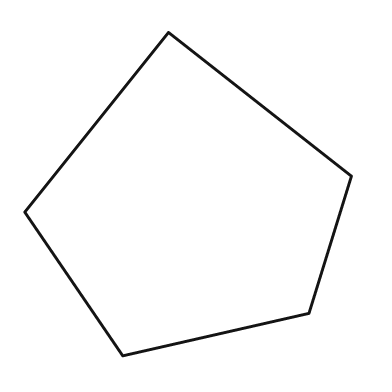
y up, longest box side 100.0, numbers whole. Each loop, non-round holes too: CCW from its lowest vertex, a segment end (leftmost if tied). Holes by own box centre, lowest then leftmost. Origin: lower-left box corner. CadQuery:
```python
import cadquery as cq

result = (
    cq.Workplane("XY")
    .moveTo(30.0, 0.0)
    .lineTo(87.0, 13.0)
    .lineTo(100.0, 55.0)
    .lineTo(44.0, 99.0)
    .lineTo(0.0, 44.0)
    .close()
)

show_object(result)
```